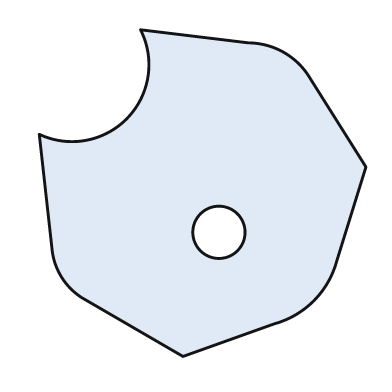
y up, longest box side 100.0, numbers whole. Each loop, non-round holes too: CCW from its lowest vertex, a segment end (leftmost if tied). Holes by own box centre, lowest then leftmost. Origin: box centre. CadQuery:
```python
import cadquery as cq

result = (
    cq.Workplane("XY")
    .moveTo(-6.0, -50.0)
    .lineTo(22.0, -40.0)
    .threePointArc((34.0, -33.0), (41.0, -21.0))
    .lineTo(50.0, 8.0)
    .lineTo(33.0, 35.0)
    .threePointArc((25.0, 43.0), (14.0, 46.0))
    .lineTo(-19.0, 50.0)
    .threePointArc((-23.0, 23.0), (-50.0, 18.0))
    .lineTo(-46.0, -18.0)
    .threePointArc((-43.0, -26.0), (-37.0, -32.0))
    .close()
    .moveTo(5.0, -12.0)
    .circle(8.0)
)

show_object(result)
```